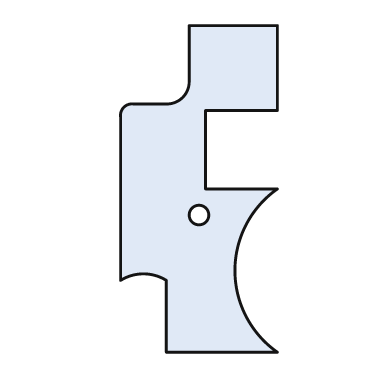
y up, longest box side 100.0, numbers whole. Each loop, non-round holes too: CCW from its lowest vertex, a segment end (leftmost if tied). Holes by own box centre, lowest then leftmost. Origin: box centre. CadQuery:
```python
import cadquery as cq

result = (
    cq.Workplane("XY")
    .moveTo(-10.0, -50.0)
    .lineTo(24.0, -50.0)
    .threePointArc((11.0, -25.0), (24.0, 0.0))
    .lineTo(2.0, 0.0)
    .lineTo(2.0, 24.0)
    .lineTo(24.0, 24.0)
    .lineTo(24.0, 50.0)
    .lineTo(-3.0, 50.0)
    .lineTo(-3.0, 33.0)
    .threePointArc((-5.0, 28.0), (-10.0, 26.0))
    .lineTo(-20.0, 26.0)
    .threePointArc((-23.0, 25.0), (-24.0, 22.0))
    .lineTo(-24.0, -28.0)
    .threePointArc((-17.0, -26.0), (-10.0, -28.0))
    .close()
    .moveTo(0.0, -8.0)
    .circle(3.0)
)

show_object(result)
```